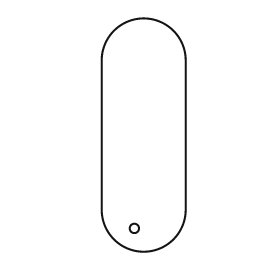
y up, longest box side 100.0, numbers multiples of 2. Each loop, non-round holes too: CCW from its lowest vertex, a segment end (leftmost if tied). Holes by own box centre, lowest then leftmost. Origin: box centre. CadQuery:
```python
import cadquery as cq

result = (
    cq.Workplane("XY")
    .moveTo(-18.0, -32.0)
    .threePointArc((0.0, -50.0), (18.0, -32.0))
    .lineTo(18.0, 32.0)
    .threePointArc((0.0, 50.0), (-18.0, 32.0))
    .close()
    .moveTo(-4.0, -40.0)
    .circle(2.0)
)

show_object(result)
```